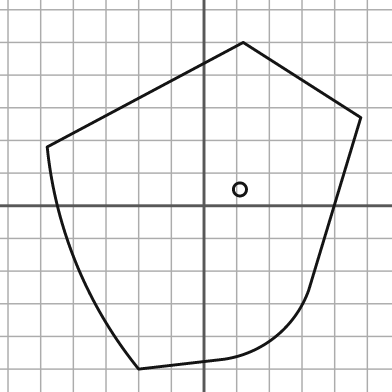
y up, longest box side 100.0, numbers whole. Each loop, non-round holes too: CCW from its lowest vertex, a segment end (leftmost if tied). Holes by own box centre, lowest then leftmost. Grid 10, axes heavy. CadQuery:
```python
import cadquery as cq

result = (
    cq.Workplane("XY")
    .moveTo(-20.0, -50.0)
    .lineTo(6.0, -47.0)
    .threePointArc((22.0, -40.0), (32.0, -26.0))
    .lineTo(48.0, 27.0)
    .lineTo(12.0, 50.0)
    .lineTo(-48.0, 18.0)
    .threePointArc((-39.0, -18.0), (-20.0, -50.0))
    .close()
    .moveTo(11.0, 5.0)
    .circle(2.0)
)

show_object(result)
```